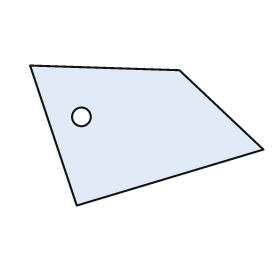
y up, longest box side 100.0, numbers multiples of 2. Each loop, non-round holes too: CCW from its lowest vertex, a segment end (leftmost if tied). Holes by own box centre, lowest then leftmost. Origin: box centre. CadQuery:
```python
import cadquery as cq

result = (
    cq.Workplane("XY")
    .moveTo(-30.0, -30.0)
    .lineTo(50.0, -6.0)
    .lineTo(14.0, 28.0)
    .lineTo(-50.0, 30.0)
    .close()
    .moveTo(-28.0, 8.0)
    .circle(4.0)
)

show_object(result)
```